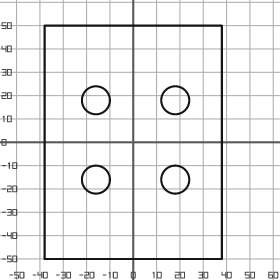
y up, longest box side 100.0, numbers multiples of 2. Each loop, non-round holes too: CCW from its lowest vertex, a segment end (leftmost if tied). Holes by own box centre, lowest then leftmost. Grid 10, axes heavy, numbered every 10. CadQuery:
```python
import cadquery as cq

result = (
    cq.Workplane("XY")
    .moveTo(-38.0, -50.0)
    .lineTo(38.0, -50.0)
    .lineTo(38.0, 50.0)
    .lineTo(-38.0, 50.0)
    .close()
    .moveTo(-16.0, -16.0)
    .circle(6.0)
    .moveTo(18.0, -16.0)
    .circle(6.0)
    .moveTo(-16.0, 18.0)
    .circle(6.0)
    .moveTo(18.0, 18.0)
    .circle(6.0)
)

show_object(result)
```